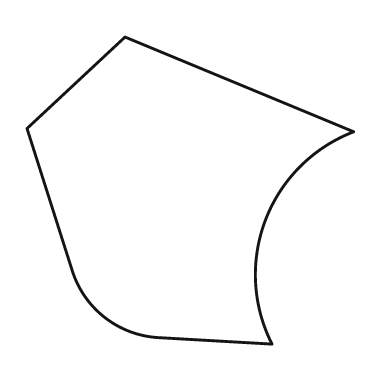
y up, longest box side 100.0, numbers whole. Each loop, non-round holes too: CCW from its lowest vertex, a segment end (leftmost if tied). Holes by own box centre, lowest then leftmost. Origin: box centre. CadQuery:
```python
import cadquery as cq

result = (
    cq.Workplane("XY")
    .moveTo(25.0, -47.0)
    .threePointArc((23.0, -9.0), (50.0, 18.0))
    .lineTo(-20.0, 47.0)
    .lineTo(-50.0, 19.0)
    .lineTo(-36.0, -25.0)
    .threePointArc((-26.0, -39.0), (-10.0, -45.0))
    .close()
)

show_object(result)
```